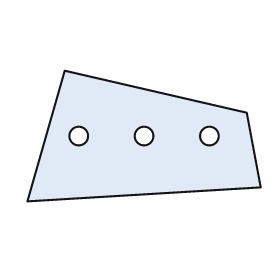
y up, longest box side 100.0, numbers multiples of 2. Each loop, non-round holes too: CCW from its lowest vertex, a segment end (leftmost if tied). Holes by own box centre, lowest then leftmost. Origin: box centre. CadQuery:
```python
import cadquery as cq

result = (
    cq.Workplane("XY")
    .moveTo(-50.0, -28.0)
    .lineTo(50.0, -22.0)
    .lineTo(44.0, 10.0)
    .lineTo(-34.0, 28.0)
    .close()
    .moveTo(-28.0, 0.0)
    .circle(4.0)
    .moveTo(0.0, 0.0)
    .circle(4.0)
    .moveTo(28.0, 0.0)
    .circle(4.0)
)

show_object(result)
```